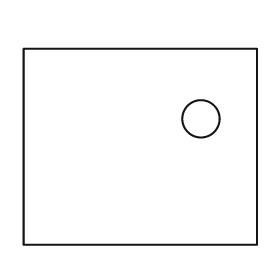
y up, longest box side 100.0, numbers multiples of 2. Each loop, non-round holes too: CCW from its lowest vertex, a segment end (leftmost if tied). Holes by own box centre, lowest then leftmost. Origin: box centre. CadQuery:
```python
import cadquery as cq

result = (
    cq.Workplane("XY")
    .moveTo(-50.0, -42.0)
    .lineTo(50.0, -42.0)
    .lineTo(50.0, 42.0)
    .lineTo(-50.0, 42.0)
    .close()
    .moveTo(26.0, 12.0)
    .circle(8.0)
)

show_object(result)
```